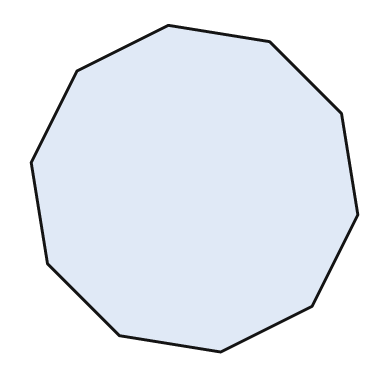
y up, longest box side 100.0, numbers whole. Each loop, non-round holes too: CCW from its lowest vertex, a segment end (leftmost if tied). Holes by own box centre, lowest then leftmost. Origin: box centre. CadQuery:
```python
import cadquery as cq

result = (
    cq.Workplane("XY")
    .moveTo(8.0, -50.0)
    .lineTo(36.0, -36.0)
    .lineTo(50.0, -8.0)
    .lineTo(45.0, 23.0)
    .lineTo(23.0, 45.0)
    .lineTo(-8.0, 50.0)
    .lineTo(-36.0, 36.0)
    .lineTo(-50.0, 8.0)
    .lineTo(-45.0, -23.0)
    .lineTo(-23.0, -45.0)
    .close()
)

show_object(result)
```